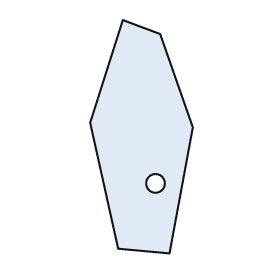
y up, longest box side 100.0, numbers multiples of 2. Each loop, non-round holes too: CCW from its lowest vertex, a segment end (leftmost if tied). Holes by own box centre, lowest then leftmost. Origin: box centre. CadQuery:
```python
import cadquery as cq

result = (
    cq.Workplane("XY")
    .moveTo(12.0, -50.0)
    .lineTo(22.0, 4.0)
    .lineTo(8.0, 44.0)
    .lineTo(-8.0, 50.0)
    .lineTo(-22.0, 6.0)
    .lineTo(-10.0, -48.0)
    .close()
    .moveTo(6.0, -20.0)
    .circle(4.0)
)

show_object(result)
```